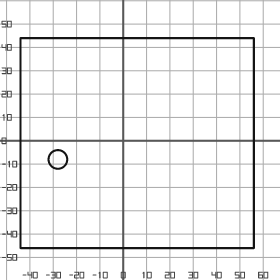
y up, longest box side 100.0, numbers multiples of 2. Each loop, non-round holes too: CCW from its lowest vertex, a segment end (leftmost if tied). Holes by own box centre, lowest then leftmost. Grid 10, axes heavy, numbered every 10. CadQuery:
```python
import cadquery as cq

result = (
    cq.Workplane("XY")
    .moveTo(-44.0, -46.0)
    .lineTo(56.0, -46.0)
    .lineTo(56.0, 44.0)
    .lineTo(-44.0, 44.0)
    .close()
    .moveTo(-28.0, -8.0)
    .circle(4.0)
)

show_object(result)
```